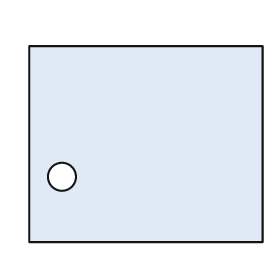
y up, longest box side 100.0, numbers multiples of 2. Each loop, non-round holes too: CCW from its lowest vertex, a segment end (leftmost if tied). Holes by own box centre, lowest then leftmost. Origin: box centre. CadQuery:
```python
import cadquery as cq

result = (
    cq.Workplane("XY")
    .moveTo(-50.0, -42.0)
    .lineTo(50.0, -42.0)
    .lineTo(50.0, 42.0)
    .lineTo(-50.0, 42.0)
    .close()
    .moveTo(-36.0, -14.0)
    .circle(6.0)
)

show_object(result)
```